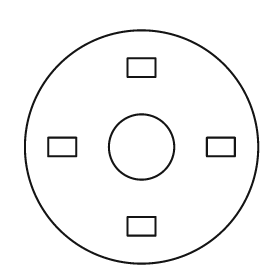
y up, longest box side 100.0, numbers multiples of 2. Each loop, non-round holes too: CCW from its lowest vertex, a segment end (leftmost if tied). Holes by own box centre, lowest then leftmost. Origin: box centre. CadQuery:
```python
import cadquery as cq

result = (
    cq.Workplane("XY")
    .moveTo(0.0, 0.0)
    .circle(50.0)
    .moveTo(-6.0, -38.0)
    .lineTo(6.0, -38.0)
    .lineTo(6.0, -30.0)
    .lineTo(-6.0, -30.0)
    .close()
    .moveTo(-40.0, -4.0)
    .lineTo(-28.0, -4.0)
    .lineTo(-28.0, 4.0)
    .lineTo(-40.0, 4.0)
    .close()
    .moveTo(0.0, 0.0)
    .circle(14.0)
    .moveTo(28.0, -4.0)
    .lineTo(40.0, -4.0)
    .lineTo(40.0, 4.0)
    .lineTo(28.0, 4.0)
    .close()
    .moveTo(-6.0, 30.0)
    .lineTo(6.0, 30.0)
    .lineTo(6.0, 38.0)
    .lineTo(-6.0, 38.0)
    .close()
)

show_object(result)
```